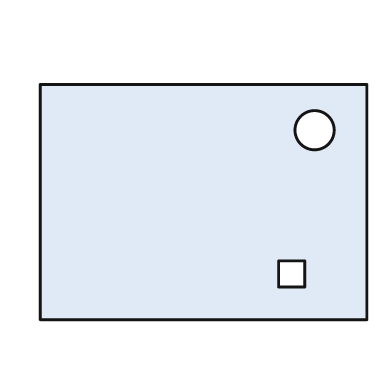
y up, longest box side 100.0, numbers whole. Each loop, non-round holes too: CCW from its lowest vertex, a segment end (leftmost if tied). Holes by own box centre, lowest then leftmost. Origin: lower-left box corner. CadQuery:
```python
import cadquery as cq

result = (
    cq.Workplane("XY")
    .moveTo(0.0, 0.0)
    .lineTo(100.0, 0.0)
    .lineTo(100.0, 72.0)
    .lineTo(0.0, 72.0)
    .close()
    .moveTo(73.0, 10.0)
    .lineTo(81.0, 10.0)
    .lineTo(81.0, 18.0)
    .lineTo(73.0, 18.0)
    .close()
    .moveTo(84.0, 58.0)
    .circle(6.0)
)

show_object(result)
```